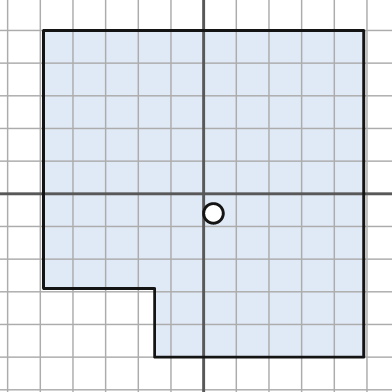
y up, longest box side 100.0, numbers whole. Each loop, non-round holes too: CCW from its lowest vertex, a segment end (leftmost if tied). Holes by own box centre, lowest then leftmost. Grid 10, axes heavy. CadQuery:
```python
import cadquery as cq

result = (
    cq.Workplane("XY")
    .moveTo(-15.0, -50.0)
    .lineTo(49.0, -50.0)
    .lineTo(49.0, 50.0)
    .lineTo(-49.0, 50.0)
    .lineTo(-49.0, -29.0)
    .lineTo(-15.0, -29.0)
    .close()
    .moveTo(3.0, -6.0)
    .circle(3.0)
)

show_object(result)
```